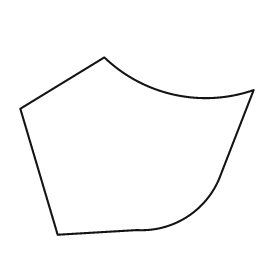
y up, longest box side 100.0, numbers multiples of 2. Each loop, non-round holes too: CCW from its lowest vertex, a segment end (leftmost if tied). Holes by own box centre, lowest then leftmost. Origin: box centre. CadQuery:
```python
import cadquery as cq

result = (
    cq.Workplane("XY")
    .moveTo(-34.0, -38.0)
    .lineTo(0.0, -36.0)
    .threePointArc((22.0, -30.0), (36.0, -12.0))
    .lineTo(50.0, 24.0)
    .threePointArc((16.0, 22.0), (-14.0, 38.0))
    .lineTo(-50.0, 16.0)
    .close()
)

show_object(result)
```